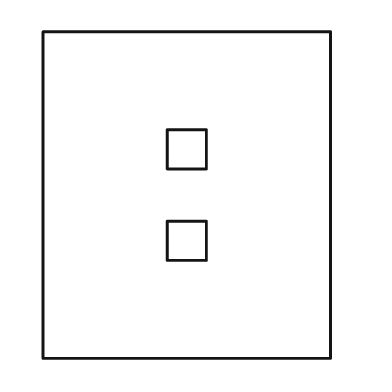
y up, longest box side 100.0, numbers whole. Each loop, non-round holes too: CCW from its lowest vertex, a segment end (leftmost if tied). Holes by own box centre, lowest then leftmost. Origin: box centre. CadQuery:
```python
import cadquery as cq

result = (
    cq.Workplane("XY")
    .moveTo(-44.0, -50.0)
    .lineTo(44.0, -50.0)
    .lineTo(44.0, 50.0)
    .lineTo(-44.0, 50.0)
    .close()
    .moveTo(-6.0, -20.0)
    .lineTo(6.0, -20.0)
    .lineTo(6.0, -8.0)
    .lineTo(-6.0, -8.0)
    .close()
    .moveTo(-6.0, 8.0)
    .lineTo(6.0, 8.0)
    .lineTo(6.0, 20.0)
    .lineTo(-6.0, 20.0)
    .close()
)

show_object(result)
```